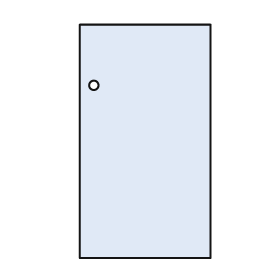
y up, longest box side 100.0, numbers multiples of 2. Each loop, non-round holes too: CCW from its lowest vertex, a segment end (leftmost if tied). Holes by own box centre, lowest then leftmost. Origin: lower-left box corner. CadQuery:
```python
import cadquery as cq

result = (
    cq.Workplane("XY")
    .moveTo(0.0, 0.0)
    .lineTo(56.0, 0.0)
    .lineTo(56.0, 100.0)
    .lineTo(0.0, 100.0)
    .close()
    .moveTo(6.0, 74.0)
    .circle(2.0)
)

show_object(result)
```